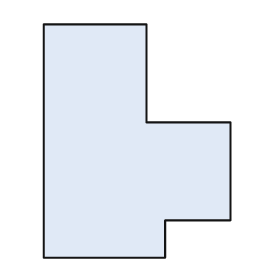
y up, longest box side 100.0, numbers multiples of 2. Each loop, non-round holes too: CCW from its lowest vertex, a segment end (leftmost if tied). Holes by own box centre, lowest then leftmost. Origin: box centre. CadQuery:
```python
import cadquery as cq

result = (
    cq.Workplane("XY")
    .moveTo(-40.0, -50.0)
    .lineTo(12.0, -50.0)
    .lineTo(12.0, -34.0)
    .lineTo(40.0, -34.0)
    .lineTo(40.0, 8.0)
    .lineTo(4.0, 8.0)
    .lineTo(4.0, 50.0)
    .lineTo(-40.0, 50.0)
    .close()
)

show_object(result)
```